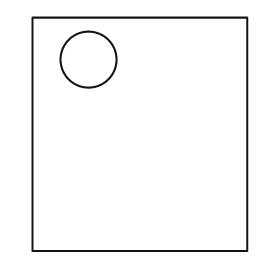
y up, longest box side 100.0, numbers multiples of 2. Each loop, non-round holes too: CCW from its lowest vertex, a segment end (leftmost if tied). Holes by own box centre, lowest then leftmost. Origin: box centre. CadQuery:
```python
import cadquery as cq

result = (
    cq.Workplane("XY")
    .moveTo(-46.0, -50.0)
    .lineTo(46.0, -50.0)
    .lineTo(46.0, 50.0)
    .lineTo(-46.0, 50.0)
    .close()
    .moveTo(-22.0, 32.0)
    .circle(12.0)
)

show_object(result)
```